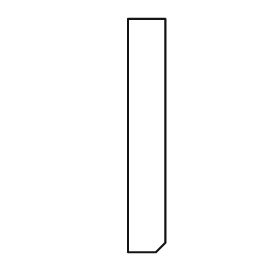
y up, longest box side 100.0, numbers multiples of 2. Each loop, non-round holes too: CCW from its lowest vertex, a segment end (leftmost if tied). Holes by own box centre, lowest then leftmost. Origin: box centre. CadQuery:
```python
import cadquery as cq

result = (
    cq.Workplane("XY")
    .moveTo(-8.0, -50.0)
    .lineTo(4.0, -50.0)
    .lineTo(8.0, -46.0)
    .lineTo(8.0, 50.0)
    .lineTo(-8.0, 50.0)
    .close()
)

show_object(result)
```